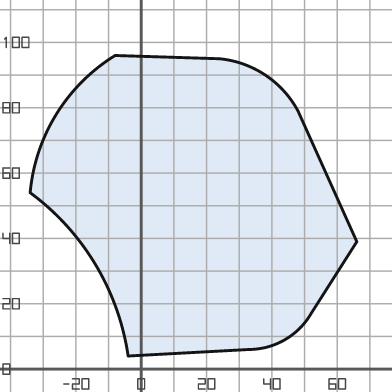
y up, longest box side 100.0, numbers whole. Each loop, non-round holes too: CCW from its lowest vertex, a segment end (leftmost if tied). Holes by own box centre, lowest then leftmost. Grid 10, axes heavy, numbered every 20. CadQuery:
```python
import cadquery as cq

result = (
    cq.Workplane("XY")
    .moveTo(-4.0, 4.0)
    .lineTo(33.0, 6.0)
    .threePointArc((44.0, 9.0), (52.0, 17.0))
    .lineTo(66.0, 39.0)
    .lineTo(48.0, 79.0)
    .threePointArc((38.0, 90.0), (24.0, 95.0))
    .lineTo(-8.0, 96.0)
    .threePointArc((-26.0, 78.0), (-34.0, 54.0))
    .threePointArc((-14.0, 32.0), (-4.0, 4.0))
    .close()
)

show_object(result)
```